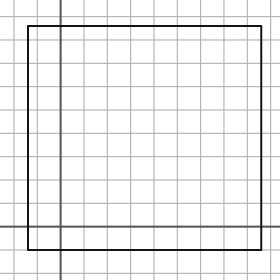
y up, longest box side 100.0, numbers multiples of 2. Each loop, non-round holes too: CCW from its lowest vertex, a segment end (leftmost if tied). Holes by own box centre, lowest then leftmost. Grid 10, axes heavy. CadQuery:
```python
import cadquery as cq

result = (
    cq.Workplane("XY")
    .moveTo(-14.0, -10.0)
    .lineTo(86.0, -10.0)
    .lineTo(86.0, 86.0)
    .lineTo(-14.0, 86.0)
    .close()
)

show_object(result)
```